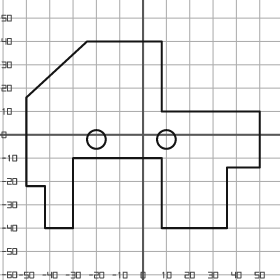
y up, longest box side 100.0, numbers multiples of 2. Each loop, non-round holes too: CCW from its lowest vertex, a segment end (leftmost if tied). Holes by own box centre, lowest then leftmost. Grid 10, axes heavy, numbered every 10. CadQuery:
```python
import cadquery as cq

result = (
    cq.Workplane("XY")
    .moveTo(-42.0, -40.0)
    .lineTo(-30.0, -40.0)
    .lineTo(-30.0, -10.0)
    .lineTo(8.0, -10.0)
    .lineTo(8.0, -40.0)
    .lineTo(36.0, -40.0)
    .lineTo(36.0, -14.0)
    .lineTo(50.0, -14.0)
    .lineTo(50.0, 10.0)
    .lineTo(8.0, 10.0)
    .lineTo(8.0, 40.0)
    .lineTo(-24.0, 40.0)
    .lineTo(-50.0, 16.0)
    .lineTo(-50.0, -22.0)
    .lineTo(-42.0, -22.0)
    .close()
    .moveTo(-20.0, -2.0)
    .circle(4.0)
    .moveTo(10.0, -2.0)
    .circle(4.0)
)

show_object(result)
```